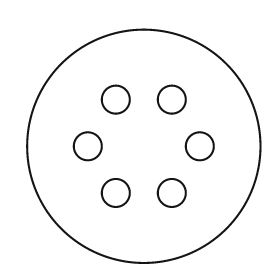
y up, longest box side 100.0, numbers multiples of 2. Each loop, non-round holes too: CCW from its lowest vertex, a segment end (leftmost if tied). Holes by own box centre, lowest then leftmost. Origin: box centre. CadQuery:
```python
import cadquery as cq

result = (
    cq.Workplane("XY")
    .moveTo(0.0, 0.0)
    .circle(50.0)
    .moveTo(-12.0, -20.0)
    .circle(6.0)
    .moveTo(12.0, -20.0)
    .circle(6.0)
    .moveTo(-24.0, 0.0)
    .circle(6.0)
    .moveTo(24.0, 0.0)
    .circle(6.0)
    .moveTo(-12.0, 20.0)
    .circle(6.0)
    .moveTo(12.0, 20.0)
    .circle(6.0)
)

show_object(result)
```